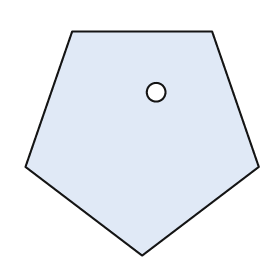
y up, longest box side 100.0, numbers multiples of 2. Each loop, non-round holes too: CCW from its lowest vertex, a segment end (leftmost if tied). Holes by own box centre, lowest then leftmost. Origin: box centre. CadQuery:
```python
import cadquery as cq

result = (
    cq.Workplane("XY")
    .moveTo(0.0, -48.0)
    .lineTo(50.0, -10.0)
    .lineTo(30.0, 48.0)
    .lineTo(-30.0, 48.0)
    .lineTo(-50.0, -10.0)
    .close()
    .moveTo(6.0, 22.0)
    .circle(4.0)
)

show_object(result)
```